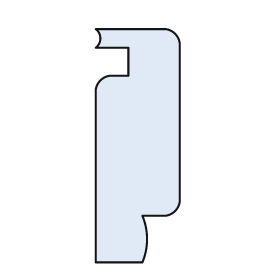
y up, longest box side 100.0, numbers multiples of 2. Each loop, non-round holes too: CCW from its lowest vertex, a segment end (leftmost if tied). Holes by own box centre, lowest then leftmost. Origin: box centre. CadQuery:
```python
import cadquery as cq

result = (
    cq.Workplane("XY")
    .moveTo(-18.0, -50.0)
    .lineTo(2.0, -50.0)
    .threePointArc((4.0, -40.0), (2.0, -30.0))
    .lineTo(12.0, -30.0)
    .threePointArc((16.0, -28.0), (18.0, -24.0))
    .lineTo(18.0, 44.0)
    .threePointArc((16.0, 48.0), (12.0, 50.0))
    .lineTo(-18.0, 50.0)
    .threePointArc((-16.0, 46.0), (-18.0, 42.0))
    .lineTo(-4.0, 42.0)
    .lineTo(-4.0, 30.0)
    .lineTo(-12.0, 30.0)
    .threePointArc((-16.0, 28.0), (-18.0, 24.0))
    .close()
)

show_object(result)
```